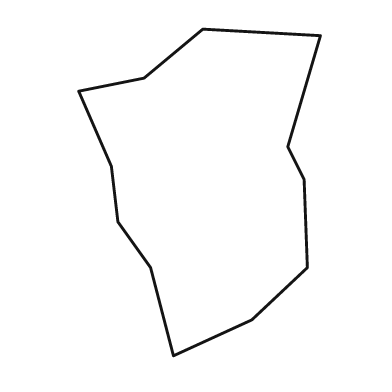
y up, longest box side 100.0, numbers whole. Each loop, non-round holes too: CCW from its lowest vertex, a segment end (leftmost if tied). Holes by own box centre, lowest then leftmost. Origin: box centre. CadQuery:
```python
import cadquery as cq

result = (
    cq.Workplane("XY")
    .moveTo(-8.0, -50.0)
    .lineTo(16.0, -39.0)
    .lineTo(33.0, -23.0)
    .lineTo(32.0, 4.0)
    .lineTo(27.0, 14.0)
    .lineTo(37.0, 48.0)
    .lineTo(1.0, 50.0)
    .lineTo(-17.0, 35.0)
    .lineTo(-37.0, 31.0)
    .lineTo(-27.0, 8.0)
    .lineTo(-25.0, -9.0)
    .lineTo(-15.0, -23.0)
    .close()
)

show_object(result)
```